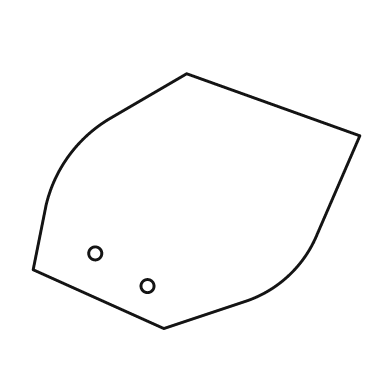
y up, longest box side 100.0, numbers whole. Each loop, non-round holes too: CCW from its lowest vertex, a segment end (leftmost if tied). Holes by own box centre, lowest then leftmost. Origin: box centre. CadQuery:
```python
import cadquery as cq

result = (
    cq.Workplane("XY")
    .moveTo(-10.0, -39.0)
    .lineTo(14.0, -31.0)
    .threePointArc((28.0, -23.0), (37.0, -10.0))
    .lineTo(50.0, 20.0)
    .lineTo(-3.0, 39.0)
    .lineTo(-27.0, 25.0)
    .threePointArc((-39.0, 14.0), (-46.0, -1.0))
    .lineTo(-50.0, -21.0)
    .close()
    .moveTo(-15.0, -26.0)
    .circle(2.0)
    .moveTo(-31.0, -16.0)
    .circle(2.0)
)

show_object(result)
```